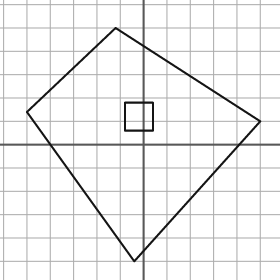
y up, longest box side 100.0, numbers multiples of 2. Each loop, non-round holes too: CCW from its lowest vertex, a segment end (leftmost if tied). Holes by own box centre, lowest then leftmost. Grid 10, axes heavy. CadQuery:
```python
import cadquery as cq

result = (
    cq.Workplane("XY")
    .moveTo(-4.0, -50.0)
    .lineTo(50.0, 10.0)
    .lineTo(-12.0, 50.0)
    .lineTo(-50.0, 14.0)
    .close()
    .moveTo(-8.0, 6.0)
    .lineTo(4.0, 6.0)
    .lineTo(4.0, 18.0)
    .lineTo(-8.0, 18.0)
    .close()
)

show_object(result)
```